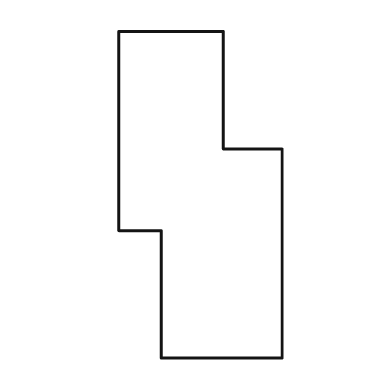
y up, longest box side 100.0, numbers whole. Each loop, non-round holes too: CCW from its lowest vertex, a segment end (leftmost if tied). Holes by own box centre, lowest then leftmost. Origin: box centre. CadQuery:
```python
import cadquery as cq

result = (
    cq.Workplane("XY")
    .moveTo(-12.0, -50.0)
    .lineTo(25.0, -50.0)
    .lineTo(25.0, 14.0)
    .lineTo(7.0, 14.0)
    .lineTo(7.0, 50.0)
    .lineTo(-25.0, 50.0)
    .lineTo(-25.0, -11.0)
    .lineTo(-12.0, -11.0)
    .close()
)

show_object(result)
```